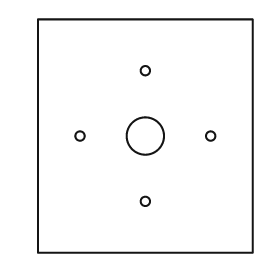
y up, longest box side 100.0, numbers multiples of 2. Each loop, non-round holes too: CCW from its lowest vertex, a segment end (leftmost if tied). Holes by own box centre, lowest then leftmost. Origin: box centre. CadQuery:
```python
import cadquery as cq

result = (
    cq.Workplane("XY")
    .moveTo(-46.0, -50.0)
    .lineTo(46.0, -50.0)
    .lineTo(46.0, 50.0)
    .lineTo(-46.0, 50.0)
    .close()
    .moveTo(0.0, -28.0)
    .circle(2.0)
    .moveTo(-28.0, 0.0)
    .circle(2.0)
    .moveTo(0.0, 0.0)
    .circle(8.0)
    .moveTo(28.0, 0.0)
    .circle(2.0)
    .moveTo(0.0, 28.0)
    .circle(2.0)
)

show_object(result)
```